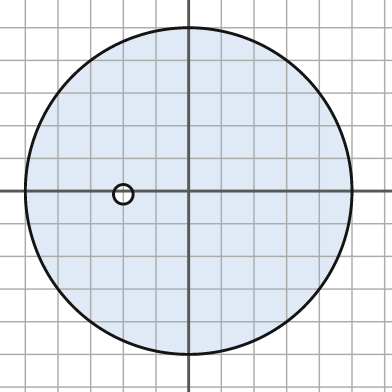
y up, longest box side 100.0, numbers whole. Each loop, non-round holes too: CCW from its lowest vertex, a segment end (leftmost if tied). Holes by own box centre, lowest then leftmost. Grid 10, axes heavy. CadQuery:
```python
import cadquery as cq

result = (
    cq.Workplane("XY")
    .moveTo(0.0, 0.0)
    .circle(50.0)
    .moveTo(-20.0, -1.0)
    .circle(3.0)
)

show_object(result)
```